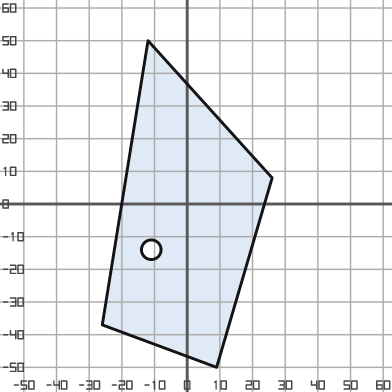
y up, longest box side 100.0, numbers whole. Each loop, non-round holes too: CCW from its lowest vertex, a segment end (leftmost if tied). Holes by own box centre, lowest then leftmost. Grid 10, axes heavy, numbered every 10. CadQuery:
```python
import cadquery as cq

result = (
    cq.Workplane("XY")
    .moveTo(9.0, -50.0)
    .lineTo(26.0, 8.0)
    .lineTo(-12.0, 50.0)
    .lineTo(-26.0, -37.0)
    .close()
    .moveTo(-11.0, -14.0)
    .circle(3.0)
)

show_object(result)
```